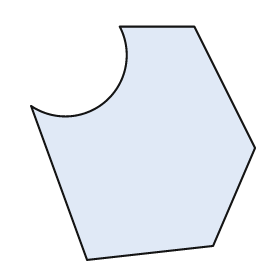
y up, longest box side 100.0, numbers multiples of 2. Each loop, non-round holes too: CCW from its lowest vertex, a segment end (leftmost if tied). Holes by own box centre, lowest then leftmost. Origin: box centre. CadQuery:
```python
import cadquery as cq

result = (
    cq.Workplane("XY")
    .moveTo(-24.0, -50.0)
    .lineTo(30.0, -44.0)
    .lineTo(48.0, -2.0)
    .lineTo(22.0, 50.0)
    .lineTo(-10.0, 50.0)
    .threePointArc((-16.0, 18.0), (-48.0, 16.0))
    .close()
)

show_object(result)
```